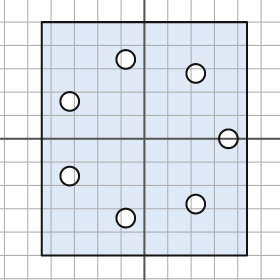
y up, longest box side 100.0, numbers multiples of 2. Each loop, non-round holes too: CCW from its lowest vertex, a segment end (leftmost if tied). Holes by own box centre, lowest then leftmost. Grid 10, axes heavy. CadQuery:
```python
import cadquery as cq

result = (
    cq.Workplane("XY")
    .moveTo(-44.0, -50.0)
    .lineTo(44.0, -50.0)
    .lineTo(44.0, 50.0)
    .lineTo(-44.0, 50.0)
    .close()
    .moveTo(-8.0, -34.0)
    .circle(4.0)
    .moveTo(22.0, -28.0)
    .circle(4.0)
    .moveTo(-32.0, -16.0)
    .circle(4.0)
    .moveTo(36.0, 0.0)
    .circle(4.0)
    .moveTo(-32.0, 16.0)
    .circle(4.0)
    .moveTo(22.0, 28.0)
    .circle(4.0)
    .moveTo(-8.0, 34.0)
    .circle(4.0)
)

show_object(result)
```